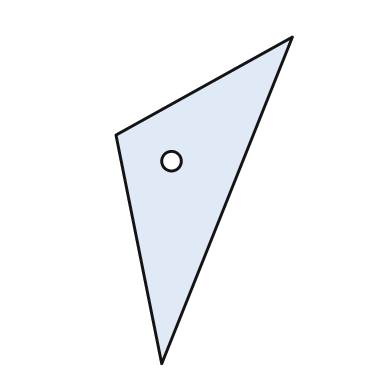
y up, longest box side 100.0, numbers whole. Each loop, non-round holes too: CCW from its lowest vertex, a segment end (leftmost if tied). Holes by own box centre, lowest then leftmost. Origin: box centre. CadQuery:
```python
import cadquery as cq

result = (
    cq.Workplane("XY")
    .moveTo(-13.0, -50.0)
    .lineTo(27.0, 50.0)
    .lineTo(-27.0, 20.0)
    .close()
    .moveTo(-10.0, 12.0)
    .circle(3.0)
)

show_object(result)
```